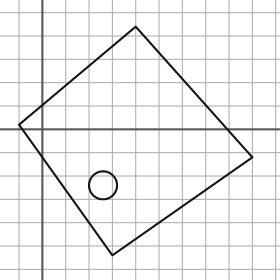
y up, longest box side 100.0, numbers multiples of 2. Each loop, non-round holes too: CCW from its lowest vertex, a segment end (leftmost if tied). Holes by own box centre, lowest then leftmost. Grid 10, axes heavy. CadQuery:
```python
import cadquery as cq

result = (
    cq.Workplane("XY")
    .moveTo(30.0, -54.0)
    .lineTo(90.0, -12.0)
    .lineTo(40.0, 44.0)
    .lineTo(-10.0, 2.0)
    .close()
    .moveTo(26.0, -24.0)
    .circle(6.0)
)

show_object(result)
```